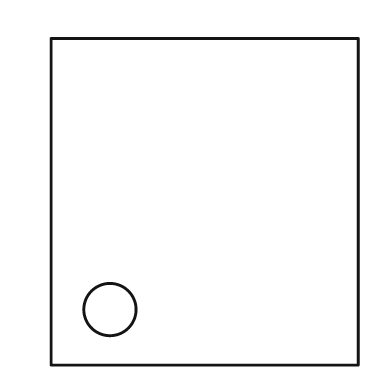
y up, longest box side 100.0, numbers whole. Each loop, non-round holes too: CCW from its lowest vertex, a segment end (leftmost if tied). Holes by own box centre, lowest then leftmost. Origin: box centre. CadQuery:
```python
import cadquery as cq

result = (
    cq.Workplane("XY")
    .moveTo(-47.0, -50.0)
    .lineTo(47.0, -50.0)
    .lineTo(47.0, 50.0)
    .lineTo(-47.0, 50.0)
    .close()
    .moveTo(-29.0, -33.0)
    .circle(8.0)
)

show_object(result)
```